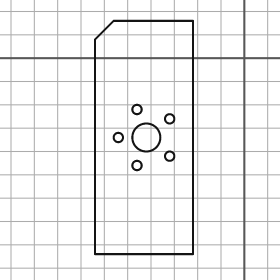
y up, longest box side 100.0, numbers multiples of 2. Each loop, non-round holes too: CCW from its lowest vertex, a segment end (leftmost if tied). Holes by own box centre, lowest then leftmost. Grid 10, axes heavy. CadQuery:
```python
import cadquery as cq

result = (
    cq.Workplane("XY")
    .moveTo(-64.0, -84.0)
    .lineTo(-22.0, -84.0)
    .lineTo(-22.0, 16.0)
    .lineTo(-56.0, 16.0)
    .lineTo(-64.0, 8.0)
    .close()
    .moveTo(-46.0, -46.0)
    .circle(2.0)
    .moveTo(-32.0, -42.0)
    .circle(2.0)
    .moveTo(-54.0, -34.0)
    .circle(2.0)
    .moveTo(-42.0, -34.0)
    .circle(6.0)
    .moveTo(-32.0, -26.0)
    .circle(2.0)
    .moveTo(-46.0, -22.0)
    .circle(2.0)
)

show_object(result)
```